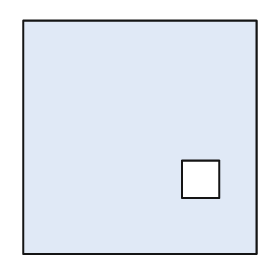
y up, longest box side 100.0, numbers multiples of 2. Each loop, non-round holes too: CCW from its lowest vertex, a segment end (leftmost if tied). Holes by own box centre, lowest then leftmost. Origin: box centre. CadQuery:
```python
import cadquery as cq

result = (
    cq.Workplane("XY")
    .moveTo(-50.0, -50.0)
    .lineTo(50.0, -50.0)
    .lineTo(50.0, 50.0)
    .lineTo(-50.0, 50.0)
    .close()
    .moveTo(18.0, -26.0)
    .lineTo(34.0, -26.0)
    .lineTo(34.0, -10.0)
    .lineTo(18.0, -10.0)
    .close()
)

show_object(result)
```